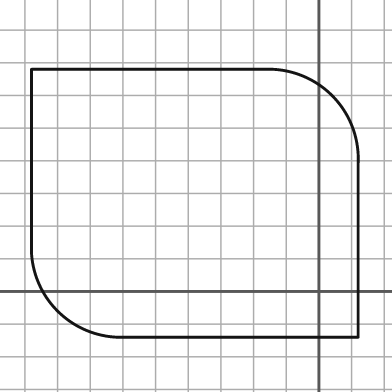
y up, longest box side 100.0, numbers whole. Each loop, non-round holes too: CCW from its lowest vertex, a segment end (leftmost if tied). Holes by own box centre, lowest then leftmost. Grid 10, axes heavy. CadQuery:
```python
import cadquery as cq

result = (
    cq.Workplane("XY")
    .moveTo(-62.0, -14.0)
    .lineTo(12.0, -14.0)
    .lineTo(12.0, 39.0)
    .threePointArc((4.0, 60.0), (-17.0, 68.0))
    .lineTo(-88.0, 68.0)
    .lineTo(-88.0, 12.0)
    .threePointArc((-80.0, -6.0), (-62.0, -14.0))
    .close()
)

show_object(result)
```